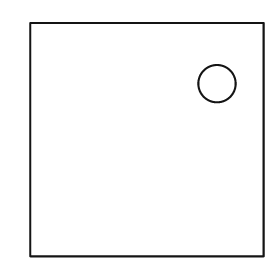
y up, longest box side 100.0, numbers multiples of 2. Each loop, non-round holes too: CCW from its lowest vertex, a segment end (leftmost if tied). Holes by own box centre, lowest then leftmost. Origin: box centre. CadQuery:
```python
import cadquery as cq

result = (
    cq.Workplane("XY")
    .moveTo(-50.0, -50.0)
    .lineTo(50.0, -50.0)
    .lineTo(50.0, 50.0)
    .lineTo(-50.0, 50.0)
    .close()
    .moveTo(30.0, 24.0)
    .circle(8.0)
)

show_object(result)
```